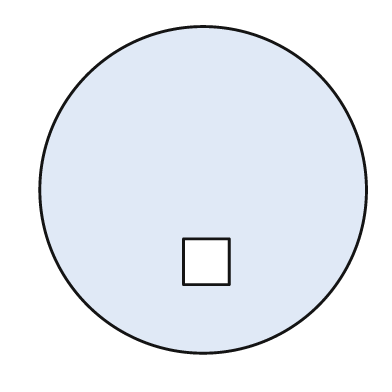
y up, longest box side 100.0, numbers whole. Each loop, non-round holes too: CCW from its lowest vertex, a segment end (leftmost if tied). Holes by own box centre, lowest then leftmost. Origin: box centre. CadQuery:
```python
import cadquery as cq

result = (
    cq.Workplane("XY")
    .moveTo(0.0, 0.0)
    .circle(50.0)
    .moveTo(-6.0, -29.0)
    .lineTo(8.0, -29.0)
    .lineTo(8.0, -15.0)
    .lineTo(-6.0, -15.0)
    .close()
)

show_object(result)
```